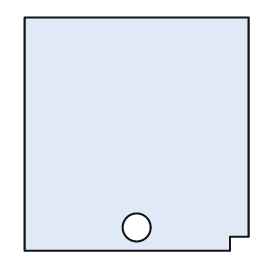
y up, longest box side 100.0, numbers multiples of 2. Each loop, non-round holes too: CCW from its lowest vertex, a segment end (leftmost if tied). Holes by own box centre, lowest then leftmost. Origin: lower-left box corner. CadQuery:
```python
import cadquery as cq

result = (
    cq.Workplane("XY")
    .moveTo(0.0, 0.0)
    .lineTo(88.0, 0.0)
    .lineTo(88.0, 6.0)
    .lineTo(96.0, 6.0)
    .lineTo(96.0, 100.0)
    .lineTo(0.0, 100.0)
    .close()
    .moveTo(48.0, 10.0)
    .circle(6.0)
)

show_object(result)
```